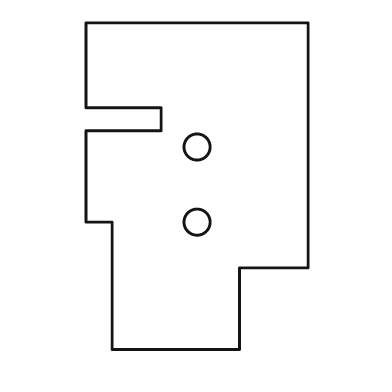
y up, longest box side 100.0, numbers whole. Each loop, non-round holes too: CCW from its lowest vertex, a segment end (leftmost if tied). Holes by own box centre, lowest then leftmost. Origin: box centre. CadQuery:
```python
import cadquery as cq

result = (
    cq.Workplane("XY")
    .moveTo(-26.0, -50.0)
    .lineTo(13.0, -50.0)
    .lineTo(13.0, -25.0)
    .lineTo(34.0, -25.0)
    .lineTo(34.0, 50.0)
    .lineTo(-34.0, 50.0)
    .lineTo(-34.0, 24.0)
    .lineTo(-11.0, 24.0)
    .lineTo(-11.0, 17.0)
    .lineTo(-34.0, 17.0)
    .lineTo(-34.0, -11.0)
    .lineTo(-26.0, -11.0)
    .close()
    .moveTo(0.0, -11.0)
    .circle(4.0)
    .moveTo(0.0, 12.0)
    .circle(4.0)
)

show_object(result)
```